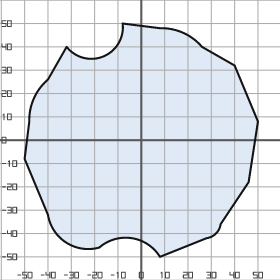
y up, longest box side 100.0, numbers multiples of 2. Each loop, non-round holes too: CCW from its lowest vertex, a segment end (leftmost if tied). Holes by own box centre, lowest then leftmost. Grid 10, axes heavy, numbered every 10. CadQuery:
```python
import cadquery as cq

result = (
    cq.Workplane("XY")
    .moveTo(8.0, -50.0)
    .lineTo(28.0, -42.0)
    .threePointArc((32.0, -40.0), (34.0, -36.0))
    .lineTo(46.0, -18.0)
    .lineTo(50.0, 8.0)
    .lineTo(40.0, 32.0)
    .lineTo(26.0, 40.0)
    .threePointArc((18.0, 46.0), (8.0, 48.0))
    .lineTo(-8.0, 50.0)
    .threePointArc((-16.0, 36.0), (-32.0, 40.0))
    .lineTo(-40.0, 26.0)
    .threePointArc((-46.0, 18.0), (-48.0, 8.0))
    .lineTo(-50.0, -8.0)
    .lineTo(-40.0, -32.0)
    .threePointArc((-32.0, -44.0), (-18.0, -46.0))
    .threePointArc((-4.0, -42.0), (8.0, -50.0))
    .close()
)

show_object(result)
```